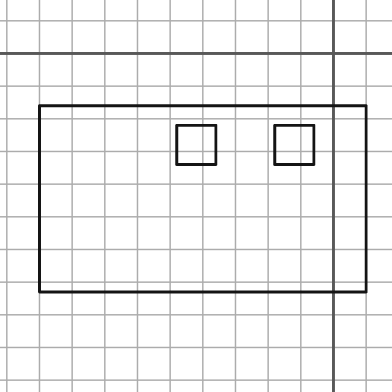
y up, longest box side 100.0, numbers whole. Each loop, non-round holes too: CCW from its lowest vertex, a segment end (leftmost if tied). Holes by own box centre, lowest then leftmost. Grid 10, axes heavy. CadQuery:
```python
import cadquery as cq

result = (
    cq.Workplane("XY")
    .moveTo(-90.0, -73.0)
    .lineTo(10.0, -73.0)
    .lineTo(10.0, -16.0)
    .lineTo(-90.0, -16.0)
    .close()
    .moveTo(-48.0, -34.0)
    .lineTo(-36.0, -34.0)
    .lineTo(-36.0, -22.0)
    .lineTo(-48.0, -22.0)
    .close()
    .moveTo(-18.0, -34.0)
    .lineTo(-6.0, -34.0)
    .lineTo(-6.0, -22.0)
    .lineTo(-18.0, -22.0)
    .close()
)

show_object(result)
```